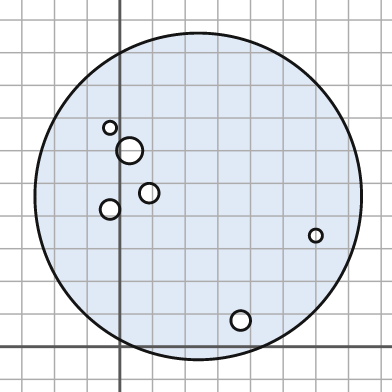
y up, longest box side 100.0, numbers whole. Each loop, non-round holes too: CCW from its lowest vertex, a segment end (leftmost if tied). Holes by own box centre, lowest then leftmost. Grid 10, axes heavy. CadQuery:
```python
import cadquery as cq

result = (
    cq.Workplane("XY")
    .moveTo(24.0, 46.0)
    .circle(50.0)
    .moveTo(37.0, 8.0)
    .circle(3.0)
    .moveTo(60.0, 34.0)
    .circle(2.0)
    .moveTo(-3.0, 42.0)
    .circle(3.0)
    .moveTo(9.0, 47.0)
    .circle(3.0)
    .moveTo(3.0, 60.0)
    .circle(4.0)
    .moveTo(-3.0, 67.0)
    .circle(2.0)
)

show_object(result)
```